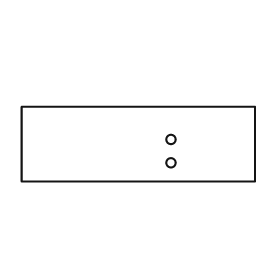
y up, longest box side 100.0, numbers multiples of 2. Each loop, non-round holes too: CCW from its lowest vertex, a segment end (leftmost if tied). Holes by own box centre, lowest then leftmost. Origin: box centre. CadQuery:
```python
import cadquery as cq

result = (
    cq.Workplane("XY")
    .moveTo(-50.0, -16.0)
    .lineTo(50.0, -16.0)
    .lineTo(50.0, 16.0)
    .lineTo(-50.0, 16.0)
    .close()
    .moveTo(14.0, -8.0)
    .circle(2.0)
    .moveTo(14.0, 2.0)
    .circle(2.0)
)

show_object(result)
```